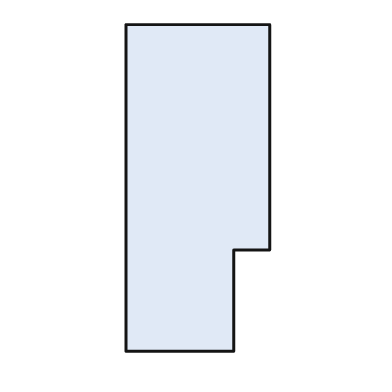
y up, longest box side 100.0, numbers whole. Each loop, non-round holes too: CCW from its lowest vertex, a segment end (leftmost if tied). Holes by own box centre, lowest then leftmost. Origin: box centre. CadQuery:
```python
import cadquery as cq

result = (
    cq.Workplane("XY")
    .moveTo(-22.0, -50.0)
    .lineTo(11.0, -50.0)
    .lineTo(11.0, -19.0)
    .lineTo(22.0, -19.0)
    .lineTo(22.0, 50.0)
    .lineTo(-22.0, 50.0)
    .close()
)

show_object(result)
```